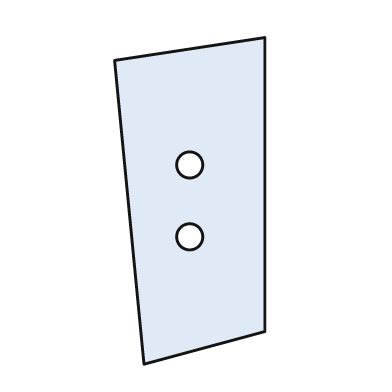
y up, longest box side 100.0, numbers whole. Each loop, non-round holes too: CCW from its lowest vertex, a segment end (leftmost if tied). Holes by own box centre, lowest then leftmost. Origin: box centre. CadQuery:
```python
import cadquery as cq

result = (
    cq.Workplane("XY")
    .moveTo(-14.0, -50.0)
    .lineTo(23.0, -40.0)
    .lineTo(23.0, 50.0)
    .lineTo(-23.0, 43.0)
    .close()
    .moveTo(0.0, -11.0)
    .circle(4.0)
    .moveTo(0.0, 11.0)
    .circle(4.0)
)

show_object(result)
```